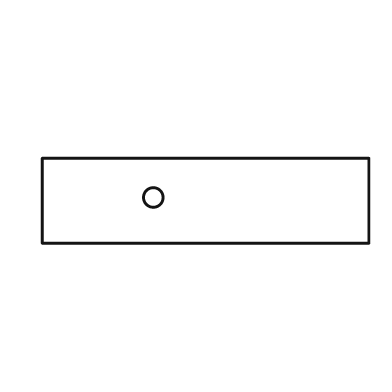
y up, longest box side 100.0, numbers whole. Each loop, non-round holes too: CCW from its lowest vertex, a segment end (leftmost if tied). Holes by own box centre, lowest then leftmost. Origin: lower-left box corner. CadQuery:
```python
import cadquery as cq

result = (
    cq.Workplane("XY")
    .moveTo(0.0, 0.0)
    .lineTo(100.0, 0.0)
    .lineTo(100.0, 26.0)
    .lineTo(0.0, 26.0)
    .close()
    .moveTo(34.0, 14.0)
    .circle(3.0)
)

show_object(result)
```